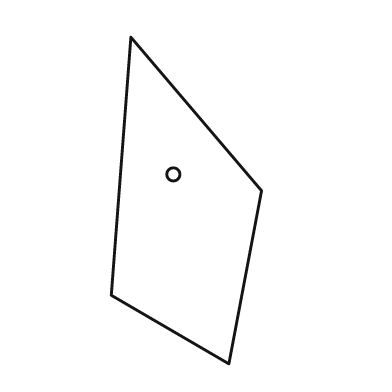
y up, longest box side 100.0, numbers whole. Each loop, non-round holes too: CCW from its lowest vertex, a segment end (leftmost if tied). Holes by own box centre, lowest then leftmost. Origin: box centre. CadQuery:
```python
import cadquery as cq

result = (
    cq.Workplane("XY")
    .moveTo(13.0, -50.0)
    .lineTo(23.0, 3.0)
    .lineTo(-17.0, 50.0)
    .lineTo(-23.0, -29.0)
    .close()
    .moveTo(-4.0, 8.0)
    .circle(2.0)
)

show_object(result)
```